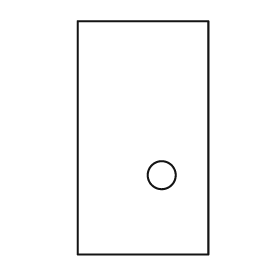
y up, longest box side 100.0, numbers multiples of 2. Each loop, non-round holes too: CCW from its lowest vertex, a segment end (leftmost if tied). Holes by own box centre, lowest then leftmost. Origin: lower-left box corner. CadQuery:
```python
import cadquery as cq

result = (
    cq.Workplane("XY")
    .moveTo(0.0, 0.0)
    .lineTo(56.0, 0.0)
    .lineTo(56.0, 100.0)
    .lineTo(0.0, 100.0)
    .close()
    .moveTo(36.0, 34.0)
    .circle(6.0)
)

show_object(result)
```